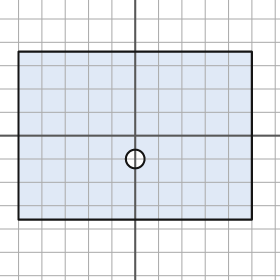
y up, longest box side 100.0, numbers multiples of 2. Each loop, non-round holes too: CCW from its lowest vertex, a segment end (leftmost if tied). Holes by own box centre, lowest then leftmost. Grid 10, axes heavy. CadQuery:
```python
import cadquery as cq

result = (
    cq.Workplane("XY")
    .moveTo(-50.0, -36.0)
    .lineTo(50.0, -36.0)
    .lineTo(50.0, 36.0)
    .lineTo(-50.0, 36.0)
    .close()
    .moveTo(0.0, -10.0)
    .circle(4.0)
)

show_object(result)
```